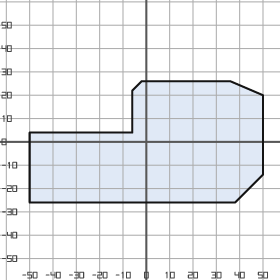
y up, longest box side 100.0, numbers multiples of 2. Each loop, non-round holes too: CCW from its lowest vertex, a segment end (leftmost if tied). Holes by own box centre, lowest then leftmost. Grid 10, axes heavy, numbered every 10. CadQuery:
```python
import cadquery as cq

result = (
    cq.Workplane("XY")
    .moveTo(-50.0, -26.0)
    .lineTo(38.0, -26.0)
    .lineTo(50.0, -14.0)
    .lineTo(50.0, 20.0)
    .lineTo(36.0, 26.0)
    .lineTo(-2.0, 26.0)
    .lineTo(-6.0, 22.0)
    .lineTo(-6.0, 4.0)
    .lineTo(-50.0, 4.0)
    .close()
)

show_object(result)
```